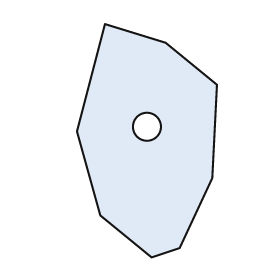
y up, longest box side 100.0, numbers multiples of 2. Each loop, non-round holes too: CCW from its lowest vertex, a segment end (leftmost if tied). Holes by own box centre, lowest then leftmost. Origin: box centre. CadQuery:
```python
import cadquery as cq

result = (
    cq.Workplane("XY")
    .moveTo(2.0, -50.0)
    .lineTo(14.0, -46.0)
    .lineTo(28.0, -16.0)
    .lineTo(30.0, 24.0)
    .lineTo(8.0, 42.0)
    .lineTo(-18.0, 50.0)
    .lineTo(-30.0, 4.0)
    .lineTo(-20.0, -32.0)
    .close()
    .moveTo(0.0, 6.0)
    .circle(6.0)
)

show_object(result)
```